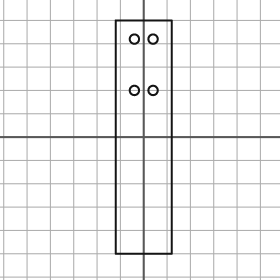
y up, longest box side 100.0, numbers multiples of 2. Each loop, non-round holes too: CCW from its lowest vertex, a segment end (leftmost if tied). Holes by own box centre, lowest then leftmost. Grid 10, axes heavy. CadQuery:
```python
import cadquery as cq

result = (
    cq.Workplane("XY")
    .moveTo(-12.0, -50.0)
    .lineTo(12.0, -50.0)
    .lineTo(12.0, 50.0)
    .lineTo(-12.0, 50.0)
    .close()
    .moveTo(-4.0, 20.0)
    .circle(2.0)
    .moveTo(4.0, 20.0)
    .circle(2.0)
    .moveTo(-4.0, 42.0)
    .circle(2.0)
    .moveTo(4.0, 42.0)
    .circle(2.0)
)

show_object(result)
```